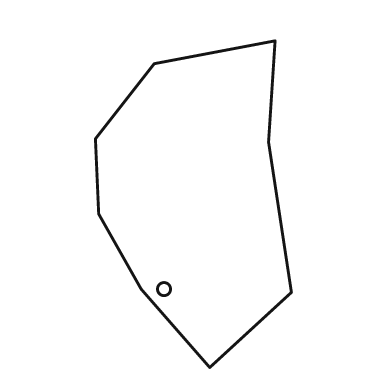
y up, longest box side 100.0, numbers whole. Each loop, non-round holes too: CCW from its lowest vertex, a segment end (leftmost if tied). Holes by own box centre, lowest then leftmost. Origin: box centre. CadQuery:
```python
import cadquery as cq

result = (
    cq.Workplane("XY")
    .moveTo(5.0, -50.0)
    .lineTo(30.0, -27.0)
    .lineTo(23.0, 19.0)
    .lineTo(25.0, 50.0)
    .lineTo(-12.0, 43.0)
    .lineTo(-30.0, 20.0)
    .lineTo(-29.0, -3.0)
    .lineTo(-16.0, -26.0)
    .close()
    .moveTo(-9.0, -26.0)
    .circle(2.0)
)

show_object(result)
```